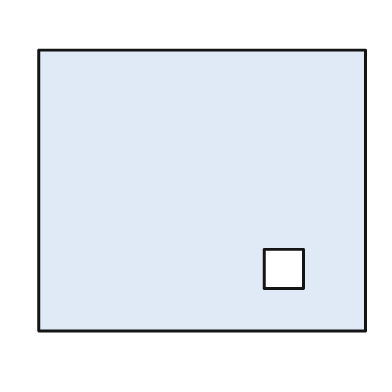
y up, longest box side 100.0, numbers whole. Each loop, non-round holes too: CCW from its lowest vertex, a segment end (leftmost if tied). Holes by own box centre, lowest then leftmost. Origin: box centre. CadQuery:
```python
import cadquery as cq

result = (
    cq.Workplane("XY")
    .moveTo(-50.0, -43.0)
    .lineTo(50.0, -43.0)
    .lineTo(50.0, 43.0)
    .lineTo(-50.0, 43.0)
    .close()
    .moveTo(19.0, -30.0)
    .lineTo(31.0, -30.0)
    .lineTo(31.0, -18.0)
    .lineTo(19.0, -18.0)
    .close()
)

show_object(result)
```